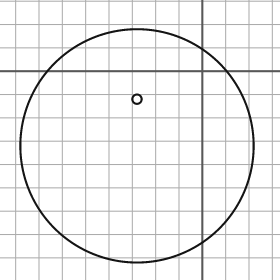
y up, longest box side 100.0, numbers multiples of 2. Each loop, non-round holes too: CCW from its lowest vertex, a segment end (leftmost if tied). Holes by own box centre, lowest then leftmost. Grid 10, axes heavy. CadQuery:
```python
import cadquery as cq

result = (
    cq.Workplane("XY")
    .moveTo(-28.0, -32.0)
    .circle(50.0)
    .moveTo(-28.0, -12.0)
    .circle(2.0)
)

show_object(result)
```